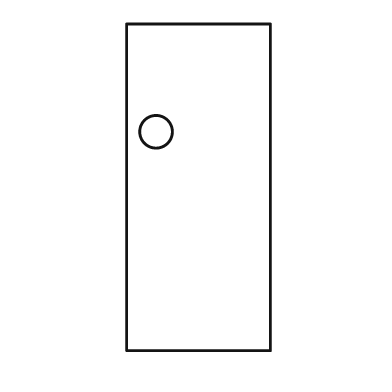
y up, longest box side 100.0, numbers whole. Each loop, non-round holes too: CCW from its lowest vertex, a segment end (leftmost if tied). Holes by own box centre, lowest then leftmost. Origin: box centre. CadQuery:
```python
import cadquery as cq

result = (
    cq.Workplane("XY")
    .moveTo(-22.0, -50.0)
    .lineTo(22.0, -50.0)
    .lineTo(22.0, 50.0)
    .lineTo(-22.0, 50.0)
    .close()
    .moveTo(-13.0, 17.0)
    .circle(5.0)
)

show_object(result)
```